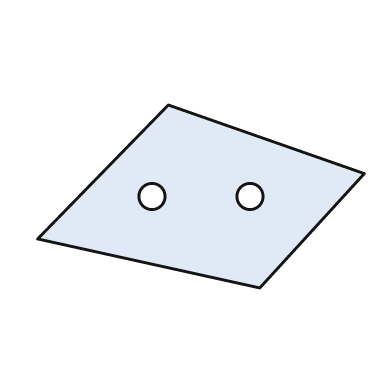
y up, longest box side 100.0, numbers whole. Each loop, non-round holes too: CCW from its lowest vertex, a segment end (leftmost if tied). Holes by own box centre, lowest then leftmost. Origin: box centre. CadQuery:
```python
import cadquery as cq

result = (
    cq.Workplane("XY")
    .moveTo(18.0, -28.0)
    .lineTo(50.0, 7.0)
    .lineTo(-10.0, 28.0)
    .lineTo(-50.0, -13.0)
    .close()
    .moveTo(-15.0, 0.0)
    .circle(4.0)
    .moveTo(15.0, 0.0)
    .circle(4.0)
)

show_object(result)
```